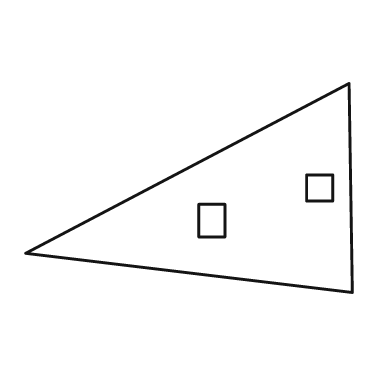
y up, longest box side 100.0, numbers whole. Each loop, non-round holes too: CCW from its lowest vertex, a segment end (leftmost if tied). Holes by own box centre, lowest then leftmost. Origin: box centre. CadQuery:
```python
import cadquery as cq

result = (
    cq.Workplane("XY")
    .moveTo(50.0, -32.0)
    .lineTo(49.0, 32.0)
    .lineTo(-50.0, -20.0)
    .close()
    .moveTo(3.0, -15.0)
    .lineTo(11.0, -15.0)
    .lineTo(11.0, -5.0)
    .lineTo(3.0, -5.0)
    .close()
    .moveTo(36.0, -4.0)
    .lineTo(44.0, -4.0)
    .lineTo(44.0, 4.0)
    .lineTo(36.0, 4.0)
    .close()
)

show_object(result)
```